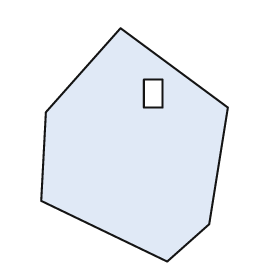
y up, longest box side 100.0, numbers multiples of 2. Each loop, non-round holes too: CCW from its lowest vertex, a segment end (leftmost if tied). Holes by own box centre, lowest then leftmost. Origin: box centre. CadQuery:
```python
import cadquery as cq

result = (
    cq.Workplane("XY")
    .moveTo(14.0, -50.0)
    .lineTo(32.0, -34.0)
    .lineTo(40.0, 16.0)
    .lineTo(-6.0, 50.0)
    .lineTo(-38.0, 14.0)
    .lineTo(-40.0, -24.0)
    .close()
    .moveTo(4.0, 16.0)
    .lineTo(12.0, 16.0)
    .lineTo(12.0, 28.0)
    .lineTo(4.0, 28.0)
    .close()
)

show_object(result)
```